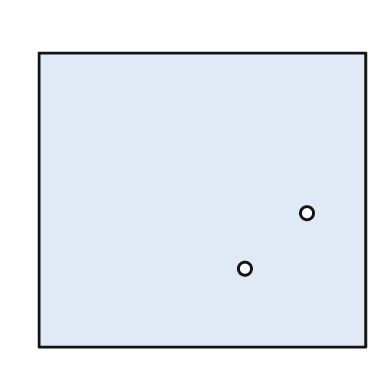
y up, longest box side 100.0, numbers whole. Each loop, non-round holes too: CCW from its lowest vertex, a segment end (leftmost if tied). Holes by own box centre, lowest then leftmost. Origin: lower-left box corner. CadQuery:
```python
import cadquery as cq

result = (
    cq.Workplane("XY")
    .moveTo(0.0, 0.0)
    .lineTo(100.0, 0.0)
    .lineTo(100.0, 90.0)
    .lineTo(0.0, 90.0)
    .close()
    .moveTo(63.0, 24.0)
    .circle(2.0)
    .moveTo(82.0, 41.0)
    .circle(2.0)
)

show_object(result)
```